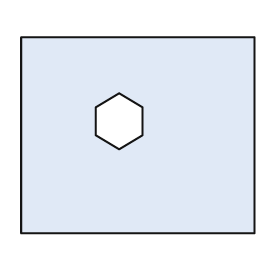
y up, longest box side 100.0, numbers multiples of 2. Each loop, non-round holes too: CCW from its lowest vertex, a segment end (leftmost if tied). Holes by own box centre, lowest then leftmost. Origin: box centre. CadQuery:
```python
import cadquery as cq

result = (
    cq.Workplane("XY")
    .moveTo(-50.0, -42.0)
    .lineTo(50.0, -42.0)
    .lineTo(50.0, 42.0)
    .lineTo(-50.0, 42.0)
    .close()
    .moveTo(-8.0, -6.0)
    .lineTo(2.0, 0.0)
    .lineTo(2.0, 12.0)
    .lineTo(-8.0, 18.0)
    .lineTo(-18.0, 12.0)
    .lineTo(-18.0, 0.0)
    .close()
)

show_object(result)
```